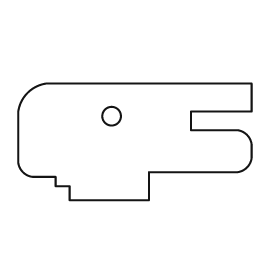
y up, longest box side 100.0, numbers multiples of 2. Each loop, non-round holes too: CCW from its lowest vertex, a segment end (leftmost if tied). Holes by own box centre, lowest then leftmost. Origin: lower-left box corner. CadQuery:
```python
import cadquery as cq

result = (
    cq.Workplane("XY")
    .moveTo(22.0, 0.0)
    .lineTo(56.0, 0.0)
    .lineTo(56.0, 12.0)
    .lineTo(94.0, 12.0)
    .threePointArc((98.0, 14.0), (100.0, 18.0))
    .lineTo(100.0, 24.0)
    .threePointArc((98.0, 28.0), (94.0, 30.0))
    .lineTo(74.0, 30.0)
    .lineTo(74.0, 38.0)
    .lineTo(100.0, 38.0)
    .lineTo(100.0, 50.0)
    .lineTo(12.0, 50.0)
    .threePointArc((4.0, 46.0), (0.0, 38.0))
    .lineTo(0.0, 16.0)
    .threePointArc((2.0, 12.0), (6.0, 10.0))
    .lineTo(16.0, 10.0)
    .lineTo(16.0, 6.0)
    .lineTo(22.0, 6.0)
    .close()
    .moveTo(40.0, 36.0)
    .circle(4.0)
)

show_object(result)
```